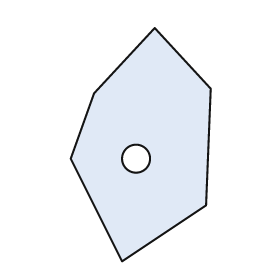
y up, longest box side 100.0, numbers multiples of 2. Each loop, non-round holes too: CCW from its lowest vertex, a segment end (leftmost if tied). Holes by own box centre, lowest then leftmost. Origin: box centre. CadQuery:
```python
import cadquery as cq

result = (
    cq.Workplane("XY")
    .moveTo(-8.0, -50.0)
    .lineTo(28.0, -26.0)
    .lineTo(30.0, 24.0)
    .lineTo(6.0, 50.0)
    .lineTo(-20.0, 22.0)
    .lineTo(-30.0, -6.0)
    .close()
    .moveTo(-2.0, -6.0)
    .circle(6.0)
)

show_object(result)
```